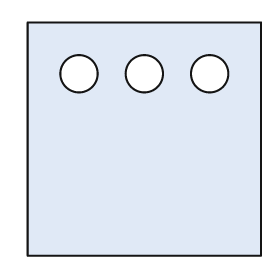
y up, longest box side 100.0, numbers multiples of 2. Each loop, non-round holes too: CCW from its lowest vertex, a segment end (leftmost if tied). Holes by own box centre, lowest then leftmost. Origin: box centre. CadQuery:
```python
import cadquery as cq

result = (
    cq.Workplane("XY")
    .moveTo(-50.0, -50.0)
    .lineTo(50.0, -50.0)
    .lineTo(50.0, 50.0)
    .lineTo(-50.0, 50.0)
    .close()
    .moveTo(-28.0, 28.0)
    .circle(8.0)
    .moveTo(0.0, 28.0)
    .circle(8.0)
    .moveTo(28.0, 28.0)
    .circle(8.0)
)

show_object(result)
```